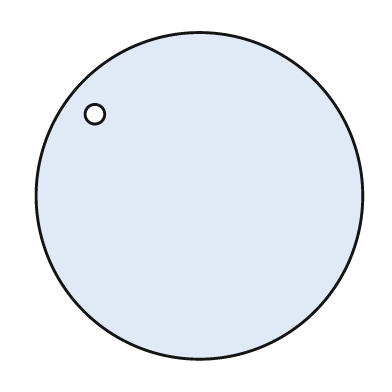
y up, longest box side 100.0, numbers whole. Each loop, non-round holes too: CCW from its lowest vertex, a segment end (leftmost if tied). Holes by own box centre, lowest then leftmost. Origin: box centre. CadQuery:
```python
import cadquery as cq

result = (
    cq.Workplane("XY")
    .moveTo(0.0, 0.0)
    .circle(50.0)
    .moveTo(-32.0, 25.0)
    .circle(3.0)
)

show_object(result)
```